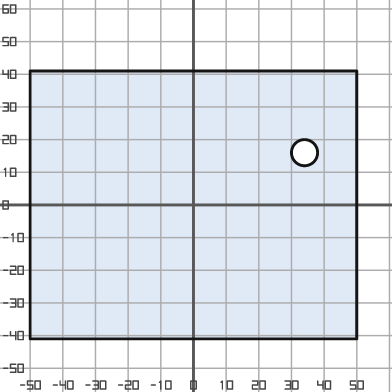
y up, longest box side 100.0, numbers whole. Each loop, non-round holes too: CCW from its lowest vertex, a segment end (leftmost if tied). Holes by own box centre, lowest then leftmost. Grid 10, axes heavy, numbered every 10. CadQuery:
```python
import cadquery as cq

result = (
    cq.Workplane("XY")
    .moveTo(-50.0, -41.0)
    .lineTo(50.0, -41.0)
    .lineTo(50.0, 41.0)
    .lineTo(-50.0, 41.0)
    .close()
    .moveTo(34.0, 16.0)
    .circle(4.0)
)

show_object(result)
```